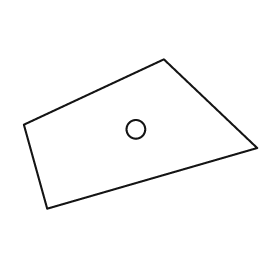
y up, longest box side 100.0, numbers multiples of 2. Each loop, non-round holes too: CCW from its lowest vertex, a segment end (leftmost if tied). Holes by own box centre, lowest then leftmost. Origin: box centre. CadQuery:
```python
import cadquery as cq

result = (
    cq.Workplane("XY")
    .moveTo(-40.0, -32.0)
    .lineTo(50.0, -6.0)
    .lineTo(10.0, 32.0)
    .lineTo(-50.0, 4.0)
    .close()
    .moveTo(-2.0, 2.0)
    .circle(4.0)
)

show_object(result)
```